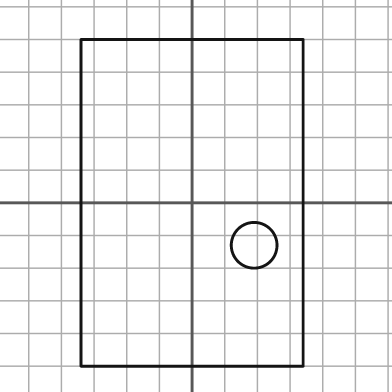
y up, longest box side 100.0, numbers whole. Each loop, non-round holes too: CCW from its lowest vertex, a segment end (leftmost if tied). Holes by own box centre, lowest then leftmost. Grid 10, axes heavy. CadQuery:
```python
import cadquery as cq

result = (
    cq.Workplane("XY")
    .moveTo(-34.0, -50.0)
    .lineTo(34.0, -50.0)
    .lineTo(34.0, 50.0)
    .lineTo(-34.0, 50.0)
    .close()
    .moveTo(19.0, -13.0)
    .circle(7.0)
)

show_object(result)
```